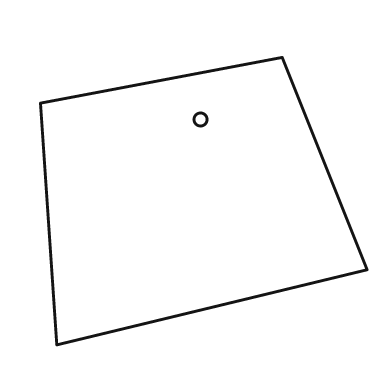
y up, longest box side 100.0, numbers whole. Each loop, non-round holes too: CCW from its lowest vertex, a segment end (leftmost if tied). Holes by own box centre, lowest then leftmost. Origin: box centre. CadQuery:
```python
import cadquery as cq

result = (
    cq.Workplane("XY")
    .moveTo(-45.0, -44.0)
    .lineTo(50.0, -21.0)
    .lineTo(24.0, 44.0)
    .lineTo(-50.0, 30.0)
    .close()
    .moveTo(-1.0, 25.0)
    .circle(2.0)
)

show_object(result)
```